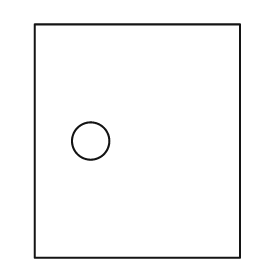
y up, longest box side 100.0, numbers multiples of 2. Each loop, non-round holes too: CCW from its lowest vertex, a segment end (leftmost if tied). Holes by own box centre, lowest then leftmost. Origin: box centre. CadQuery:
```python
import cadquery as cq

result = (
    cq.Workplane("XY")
    .moveTo(-44.0, -50.0)
    .lineTo(44.0, -50.0)
    .lineTo(44.0, 50.0)
    .lineTo(-44.0, 50.0)
    .close()
    .moveTo(-20.0, 0.0)
    .circle(8.0)
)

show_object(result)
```